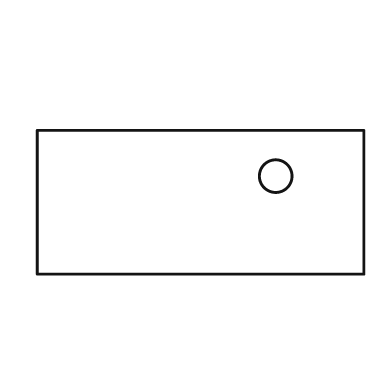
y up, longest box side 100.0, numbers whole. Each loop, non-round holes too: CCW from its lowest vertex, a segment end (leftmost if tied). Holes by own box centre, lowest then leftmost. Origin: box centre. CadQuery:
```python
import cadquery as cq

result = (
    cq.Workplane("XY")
    .moveTo(-50.0, -22.0)
    .lineTo(50.0, -22.0)
    .lineTo(50.0, 22.0)
    .lineTo(-50.0, 22.0)
    .close()
    .moveTo(23.0, 8.0)
    .circle(5.0)
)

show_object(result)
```